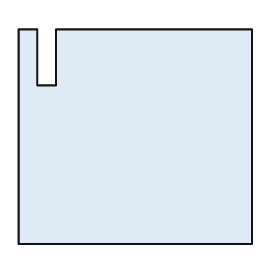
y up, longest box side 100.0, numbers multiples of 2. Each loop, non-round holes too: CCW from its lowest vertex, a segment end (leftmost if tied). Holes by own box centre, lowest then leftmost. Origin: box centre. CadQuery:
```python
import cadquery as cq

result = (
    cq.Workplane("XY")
    .moveTo(-50.0, -46.0)
    .lineTo(50.0, -46.0)
    .lineTo(50.0, 46.0)
    .lineTo(-34.0, 46.0)
    .lineTo(-34.0, 22.0)
    .lineTo(-42.0, 22.0)
    .lineTo(-42.0, 46.0)
    .lineTo(-50.0, 46.0)
    .close()
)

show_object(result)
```